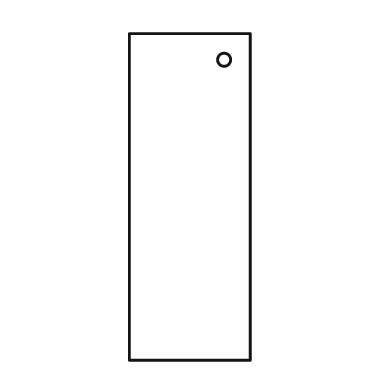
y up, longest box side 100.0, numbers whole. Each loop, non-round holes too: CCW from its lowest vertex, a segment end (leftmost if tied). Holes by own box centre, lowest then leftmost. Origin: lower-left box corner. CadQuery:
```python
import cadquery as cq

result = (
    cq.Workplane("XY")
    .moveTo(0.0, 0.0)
    .lineTo(37.0, 0.0)
    .lineTo(37.0, 100.0)
    .lineTo(0.0, 100.0)
    .close()
    .moveTo(29.0, 92.0)
    .circle(2.0)
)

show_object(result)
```